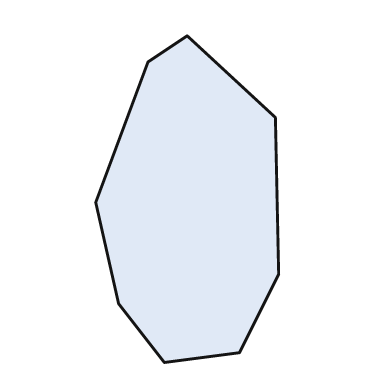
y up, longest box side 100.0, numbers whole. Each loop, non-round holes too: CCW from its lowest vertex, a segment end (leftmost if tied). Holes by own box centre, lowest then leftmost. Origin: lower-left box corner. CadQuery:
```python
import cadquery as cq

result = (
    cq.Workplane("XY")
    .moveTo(21.0, 0.0)
    .lineTo(44.0, 3.0)
    .lineTo(56.0, 27.0)
    .lineTo(55.0, 75.0)
    .lineTo(28.0, 100.0)
    .lineTo(16.0, 92.0)
    .lineTo(0.0, 49.0)
    .lineTo(7.0, 18.0)
    .close()
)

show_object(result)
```